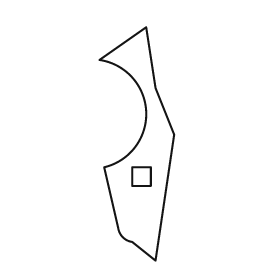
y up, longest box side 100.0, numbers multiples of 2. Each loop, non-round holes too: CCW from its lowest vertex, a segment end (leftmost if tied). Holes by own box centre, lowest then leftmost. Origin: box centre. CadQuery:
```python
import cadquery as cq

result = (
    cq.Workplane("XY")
    .moveTo(8.0, -50.0)
    .lineTo(16.0, 4.0)
    .lineTo(8.0, 24.0)
    .lineTo(4.0, 50.0)
    .lineTo(-16.0, 36.0)
    .threePointArc((4.0, 14.0), (-14.0, -10.0))
    .lineTo(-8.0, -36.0)
    .threePointArc((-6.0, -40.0), (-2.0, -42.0))
    .close()
    .moveTo(-2.0, -18.0)
    .lineTo(6.0, -18.0)
    .lineTo(6.0, -10.0)
    .lineTo(-2.0, -10.0)
    .close()
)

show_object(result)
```